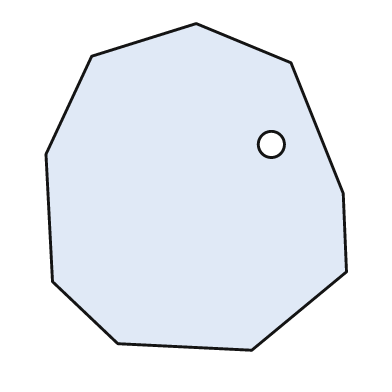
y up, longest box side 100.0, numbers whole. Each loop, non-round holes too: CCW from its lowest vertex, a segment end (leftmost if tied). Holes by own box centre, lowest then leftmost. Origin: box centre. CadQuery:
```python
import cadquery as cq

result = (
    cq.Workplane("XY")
    .moveTo(17.0, -50.0)
    .lineTo(46.0, -26.0)
    .lineTo(45.0, -2.0)
    .lineTo(29.0, 38.0)
    .lineTo(0.0, 50.0)
    .lineTo(-32.0, 40.0)
    .lineTo(-46.0, 10.0)
    .lineTo(-44.0, -29.0)
    .lineTo(-24.0, -48.0)
    .close()
    .moveTo(23.0, 13.0)
    .circle(4.0)
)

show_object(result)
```